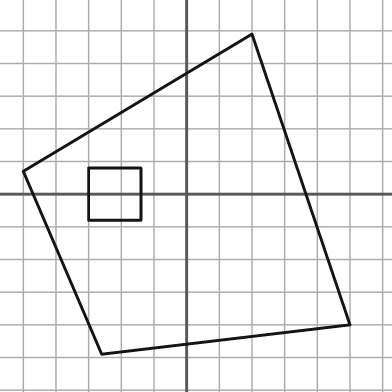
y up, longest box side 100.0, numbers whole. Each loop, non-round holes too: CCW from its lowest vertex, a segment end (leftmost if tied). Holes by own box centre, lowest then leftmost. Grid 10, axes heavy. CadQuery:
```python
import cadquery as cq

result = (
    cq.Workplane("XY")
    .moveTo(-26.0, -49.0)
    .lineTo(50.0, -40.0)
    .lineTo(20.0, 49.0)
    .lineTo(-50.0, 7.0)
    .close()
    .moveTo(-30.0, -8.0)
    .lineTo(-14.0, -8.0)
    .lineTo(-14.0, 8.0)
    .lineTo(-30.0, 8.0)
    .close()
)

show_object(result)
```